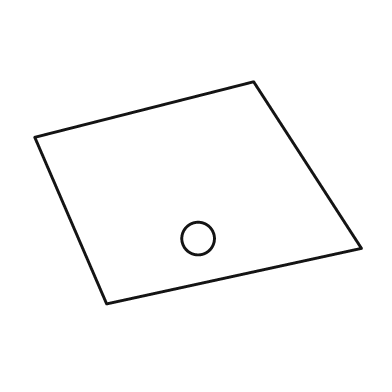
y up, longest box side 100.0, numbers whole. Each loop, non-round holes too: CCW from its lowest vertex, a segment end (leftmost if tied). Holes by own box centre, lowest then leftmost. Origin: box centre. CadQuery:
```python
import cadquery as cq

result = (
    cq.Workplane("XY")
    .moveTo(-28.0, -34.0)
    .lineTo(50.0, -17.0)
    .lineTo(17.0, 34.0)
    .lineTo(-50.0, 17.0)
    .close()
    .moveTo(0.0, -14.0)
    .circle(5.0)
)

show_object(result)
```